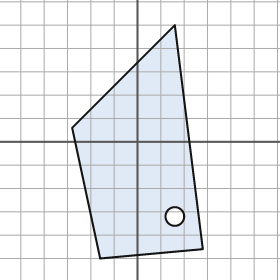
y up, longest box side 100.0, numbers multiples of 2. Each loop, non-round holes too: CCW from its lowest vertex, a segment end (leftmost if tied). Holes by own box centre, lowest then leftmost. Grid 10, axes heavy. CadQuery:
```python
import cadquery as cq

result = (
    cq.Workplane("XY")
    .moveTo(-16.0, -50.0)
    .lineTo(28.0, -46.0)
    .lineTo(16.0, 50.0)
    .lineTo(-28.0, 6.0)
    .close()
    .moveTo(16.0, -32.0)
    .circle(4.0)
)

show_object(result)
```